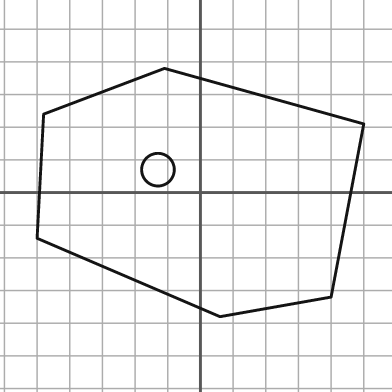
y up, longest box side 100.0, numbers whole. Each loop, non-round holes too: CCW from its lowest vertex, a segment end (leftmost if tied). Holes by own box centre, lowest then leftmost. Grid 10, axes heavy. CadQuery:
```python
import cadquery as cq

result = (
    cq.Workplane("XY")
    .moveTo(6.0, -38.0)
    .lineTo(40.0, -32.0)
    .lineTo(50.0, 21.0)
    .lineTo(-11.0, 38.0)
    .lineTo(-48.0, 24.0)
    .lineTo(-50.0, -14.0)
    .close()
    .moveTo(-13.0, 7.0)
    .circle(5.0)
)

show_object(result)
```